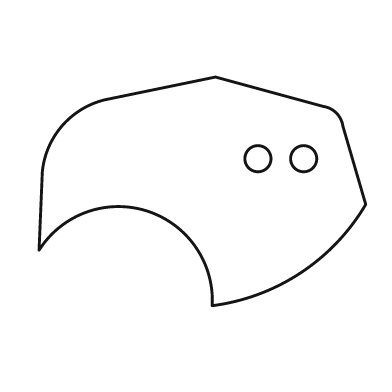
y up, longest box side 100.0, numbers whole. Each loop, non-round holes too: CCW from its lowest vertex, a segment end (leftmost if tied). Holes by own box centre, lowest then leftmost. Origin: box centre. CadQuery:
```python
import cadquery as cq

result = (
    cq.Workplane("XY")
    .moveTo(3.0, -35.0)
    .threePointArc((30.0, -25.0), (50.0, -4.0))
    .lineTo(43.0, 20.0)
    .threePointArc((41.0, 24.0), (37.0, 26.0))
    .lineTo(4.0, 35.0)
    .lineTo(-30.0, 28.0)
    .threePointArc((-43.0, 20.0), (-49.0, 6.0))
    .lineTo(-50.0, -18.0)
    .threePointArc((-17.0, -6.0), (3.0, -35.0))
    .close()
    .moveTo(17.0, 10.0)
    .circle(4.0)
    .moveTo(31.0, 10.0)
    .circle(4.0)
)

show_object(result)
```